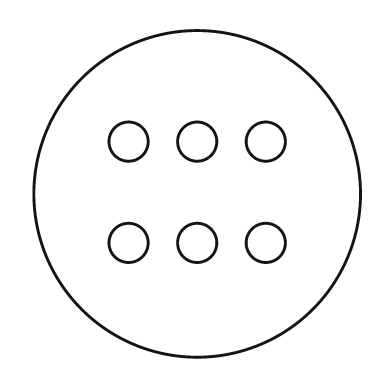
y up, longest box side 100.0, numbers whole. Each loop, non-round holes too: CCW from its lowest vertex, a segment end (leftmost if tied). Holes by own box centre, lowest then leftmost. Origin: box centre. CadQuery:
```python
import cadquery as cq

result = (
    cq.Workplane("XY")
    .moveTo(0.0, 0.0)
    .circle(50.0)
    .moveTo(-21.0, -15.0)
    .circle(6.0)
    .moveTo(0.0, -15.0)
    .circle(6.0)
    .moveTo(21.0, -15.0)
    .circle(6.0)
    .moveTo(-21.0, 16.0)
    .circle(6.0)
    .moveTo(0.0, 16.0)
    .circle(6.0)
    .moveTo(21.0, 16.0)
    .circle(6.0)
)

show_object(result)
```